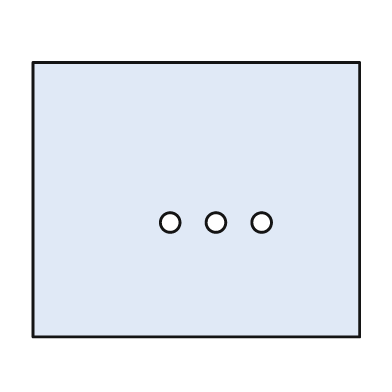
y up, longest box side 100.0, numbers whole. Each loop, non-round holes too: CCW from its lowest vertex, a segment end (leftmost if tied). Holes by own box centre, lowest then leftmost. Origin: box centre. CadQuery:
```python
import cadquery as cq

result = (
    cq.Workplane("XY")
    .moveTo(-50.0, -42.0)
    .lineTo(50.0, -42.0)
    .lineTo(50.0, 42.0)
    .lineTo(-50.0, 42.0)
    .close()
    .moveTo(-8.0, -7.0)
    .circle(3.0)
    .moveTo(6.0, -7.0)
    .circle(3.0)
    .moveTo(20.0, -7.0)
    .circle(3.0)
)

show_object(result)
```